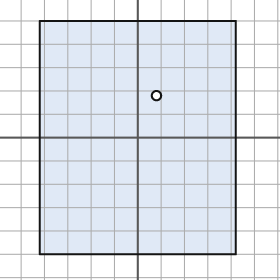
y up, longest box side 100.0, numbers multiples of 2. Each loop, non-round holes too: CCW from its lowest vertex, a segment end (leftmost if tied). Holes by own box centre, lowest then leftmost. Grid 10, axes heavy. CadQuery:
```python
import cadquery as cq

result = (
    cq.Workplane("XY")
    .moveTo(-42.0, -50.0)
    .lineTo(42.0, -50.0)
    .lineTo(42.0, 50.0)
    .lineTo(-42.0, 50.0)
    .close()
    .moveTo(8.0, 18.0)
    .circle(2.0)
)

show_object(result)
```